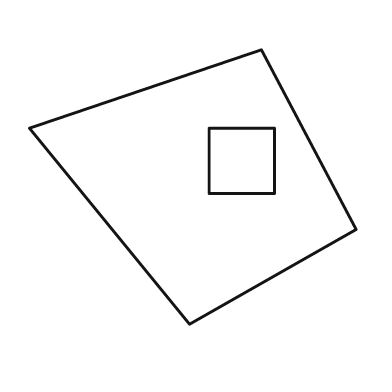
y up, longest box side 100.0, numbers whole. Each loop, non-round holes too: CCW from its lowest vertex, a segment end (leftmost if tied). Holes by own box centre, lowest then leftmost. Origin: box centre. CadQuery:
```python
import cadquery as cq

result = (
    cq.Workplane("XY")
    .moveTo(-1.0, -42.0)
    .lineTo(50.0, -13.0)
    .lineTo(21.0, 42.0)
    .lineTo(-50.0, 18.0)
    .close()
    .moveTo(5.0, -2.0)
    .lineTo(25.0, -2.0)
    .lineTo(25.0, 18.0)
    .lineTo(5.0, 18.0)
    .close()
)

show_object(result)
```